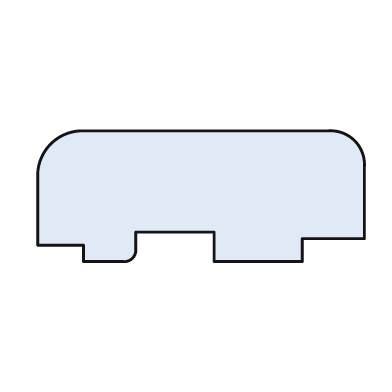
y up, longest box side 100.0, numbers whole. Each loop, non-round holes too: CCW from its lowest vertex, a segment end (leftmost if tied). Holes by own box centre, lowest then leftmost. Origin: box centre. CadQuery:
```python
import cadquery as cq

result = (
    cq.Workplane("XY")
    .moveTo(-36.0, -20.0)
    .lineTo(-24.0, -20.0)
    .threePointArc((-21.0, -19.0), (-20.0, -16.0))
    .lineTo(-20.0, -11.0)
    .lineTo(4.0, -11.0)
    .lineTo(4.0, -20.0)
    .lineTo(31.0, -20.0)
    .lineTo(31.0, -13.0)
    .lineTo(50.0, -13.0)
    .lineTo(50.0, 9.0)
    .threePointArc((47.0, 17.0), (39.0, 20.0))
    .lineTo(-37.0, 20.0)
    .threePointArc((-46.0, 16.0), (-50.0, 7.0))
    .lineTo(-50.0, -15.0)
    .lineTo(-36.0, -15.0)
    .close()
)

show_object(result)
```